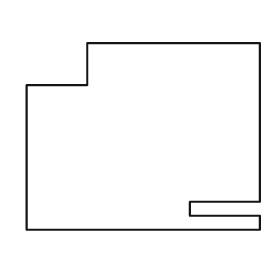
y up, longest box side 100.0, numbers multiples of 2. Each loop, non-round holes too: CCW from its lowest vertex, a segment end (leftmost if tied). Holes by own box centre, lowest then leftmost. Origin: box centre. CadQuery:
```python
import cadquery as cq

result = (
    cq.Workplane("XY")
    .moveTo(-50.0, -40.0)
    .lineTo(50.0, -40.0)
    .lineTo(50.0, -34.0)
    .lineTo(20.0, -34.0)
    .lineTo(20.0, -28.0)
    .lineTo(50.0, -28.0)
    .lineTo(50.0, 40.0)
    .lineTo(-24.0, 40.0)
    .lineTo(-24.0, 22.0)
    .lineTo(-50.0, 22.0)
    .close()
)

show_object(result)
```